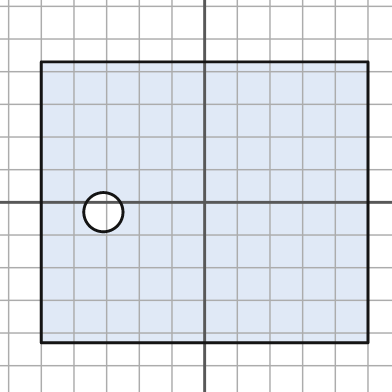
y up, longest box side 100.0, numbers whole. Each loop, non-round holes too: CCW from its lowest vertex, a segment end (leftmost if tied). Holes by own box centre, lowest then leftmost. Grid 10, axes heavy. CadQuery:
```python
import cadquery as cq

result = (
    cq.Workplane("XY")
    .moveTo(-50.0, -43.0)
    .lineTo(50.0, -43.0)
    .lineTo(50.0, 43.0)
    .lineTo(-50.0, 43.0)
    .close()
    .moveTo(-31.0, -3.0)
    .circle(6.0)
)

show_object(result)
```